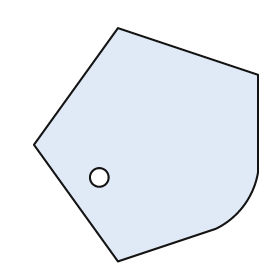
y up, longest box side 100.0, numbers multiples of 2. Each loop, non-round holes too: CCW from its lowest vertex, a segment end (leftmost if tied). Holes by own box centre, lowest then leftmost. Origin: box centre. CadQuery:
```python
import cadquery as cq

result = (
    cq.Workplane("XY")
    .moveTo(-12.0, -50.0)
    .lineTo(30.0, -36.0)
    .threePointArc((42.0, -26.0), (48.0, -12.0))
    .lineTo(48.0, 30.0)
    .lineTo(-12.0, 50.0)
    .lineTo(-48.0, 0.0)
    .close()
    .moveTo(-20.0, -14.0)
    .circle(4.0)
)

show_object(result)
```